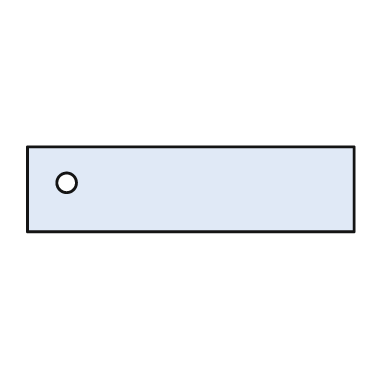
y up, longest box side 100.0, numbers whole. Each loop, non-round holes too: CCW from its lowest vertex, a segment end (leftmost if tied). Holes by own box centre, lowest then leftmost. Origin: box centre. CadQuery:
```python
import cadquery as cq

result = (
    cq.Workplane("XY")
    .moveTo(-50.0, -13.0)
    .lineTo(50.0, -13.0)
    .lineTo(50.0, 13.0)
    .lineTo(-50.0, 13.0)
    .close()
    .moveTo(-38.0, 2.0)
    .circle(3.0)
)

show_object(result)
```